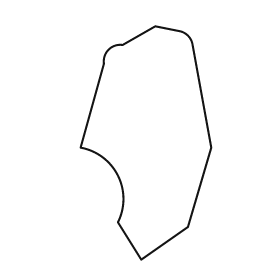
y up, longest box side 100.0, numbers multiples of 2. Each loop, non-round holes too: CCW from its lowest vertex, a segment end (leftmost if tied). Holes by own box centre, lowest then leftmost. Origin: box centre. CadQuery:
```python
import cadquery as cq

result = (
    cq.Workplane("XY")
    .moveTo(-2.0, -50.0)
    .lineTo(18.0, -36.0)
    .lineTo(28.0, -2.0)
    .lineTo(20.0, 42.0)
    .threePointArc((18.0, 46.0), (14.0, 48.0))
    .lineTo(4.0, 50.0)
    .lineTo(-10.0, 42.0)
    .threePointArc((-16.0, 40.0), (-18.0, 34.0))
    .lineTo(-28.0, -2.0)
    .threePointArc((-12.0, -14.0), (-12.0, -34.0))
    .close()
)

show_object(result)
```